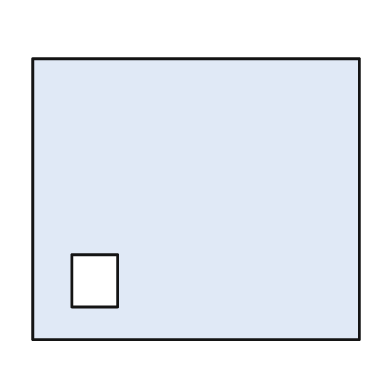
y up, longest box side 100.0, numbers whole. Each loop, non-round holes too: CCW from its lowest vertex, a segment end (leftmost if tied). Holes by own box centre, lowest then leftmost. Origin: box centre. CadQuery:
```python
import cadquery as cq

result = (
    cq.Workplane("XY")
    .moveTo(-50.0, -43.0)
    .lineTo(50.0, -43.0)
    .lineTo(50.0, 43.0)
    .lineTo(-50.0, 43.0)
    .close()
    .moveTo(-38.0, -33.0)
    .lineTo(-24.0, -33.0)
    .lineTo(-24.0, -17.0)
    .lineTo(-38.0, -17.0)
    .close()
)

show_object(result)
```